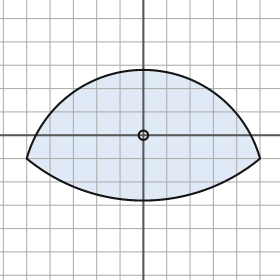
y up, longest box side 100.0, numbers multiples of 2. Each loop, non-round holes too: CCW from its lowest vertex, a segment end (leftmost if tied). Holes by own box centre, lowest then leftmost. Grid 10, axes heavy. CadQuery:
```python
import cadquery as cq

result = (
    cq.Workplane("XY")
    .moveTo(-50.0, -10.0)
    .threePointArc((0.0, -28.0), (50.0, -10.0))
    .threePointArc((0.0, 28.0), (-50.0, -10.0))
    .close()
    .moveTo(0.0, 0.0)
    .circle(2.0)
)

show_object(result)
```